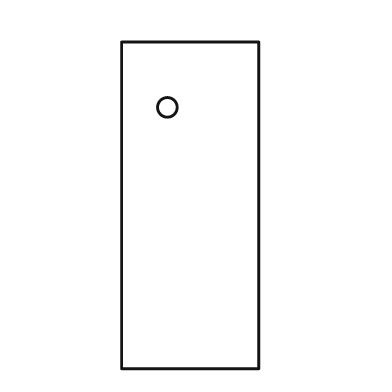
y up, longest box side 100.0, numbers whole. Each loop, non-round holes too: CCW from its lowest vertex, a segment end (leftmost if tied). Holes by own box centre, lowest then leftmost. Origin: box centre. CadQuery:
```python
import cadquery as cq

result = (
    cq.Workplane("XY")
    .moveTo(-21.0, -50.0)
    .lineTo(21.0, -50.0)
    .lineTo(21.0, 50.0)
    .lineTo(-21.0, 50.0)
    .close()
    .moveTo(-7.0, 30.0)
    .circle(3.0)
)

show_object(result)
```